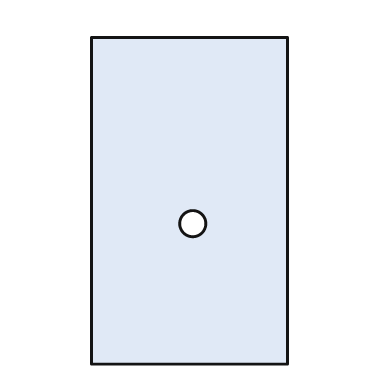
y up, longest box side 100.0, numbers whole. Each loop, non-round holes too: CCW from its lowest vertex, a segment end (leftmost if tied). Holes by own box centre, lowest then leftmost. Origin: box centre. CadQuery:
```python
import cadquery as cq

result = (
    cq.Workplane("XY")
    .moveTo(-30.0, -50.0)
    .lineTo(30.0, -50.0)
    .lineTo(30.0, 50.0)
    .lineTo(-30.0, 50.0)
    .close()
    .moveTo(1.0, -7.0)
    .circle(4.0)
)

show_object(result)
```